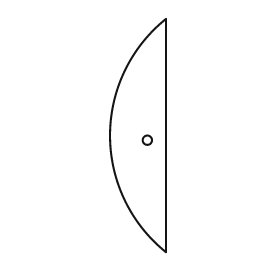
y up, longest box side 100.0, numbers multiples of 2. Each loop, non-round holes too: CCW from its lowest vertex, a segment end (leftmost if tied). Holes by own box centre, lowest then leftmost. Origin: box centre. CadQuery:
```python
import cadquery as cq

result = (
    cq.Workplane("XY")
    .moveTo(12.0, -50.0)
    .lineTo(12.0, 50.0)
    .threePointArc((-12.0, 0.0), (12.0, -50.0))
    .close()
    .moveTo(4.0, -2.0)
    .circle(2.0)
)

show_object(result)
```